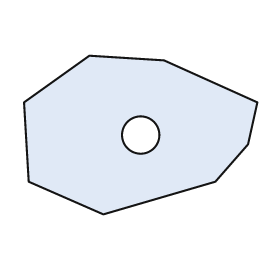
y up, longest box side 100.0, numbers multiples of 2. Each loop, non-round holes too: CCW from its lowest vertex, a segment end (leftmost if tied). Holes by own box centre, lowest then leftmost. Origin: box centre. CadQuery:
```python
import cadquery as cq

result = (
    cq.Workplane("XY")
    .moveTo(-16.0, -34.0)
    .lineTo(32.0, -20.0)
    .lineTo(46.0, -4.0)
    .lineTo(50.0, 14.0)
    .lineTo(10.0, 32.0)
    .lineTo(-22.0, 34.0)
    .lineTo(-50.0, 14.0)
    .lineTo(-48.0, -20.0)
    .close()
    .moveTo(0.0, 0.0)
    .circle(8.0)
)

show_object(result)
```